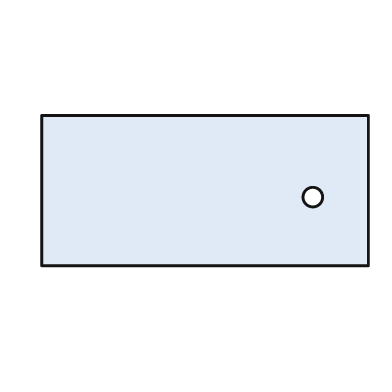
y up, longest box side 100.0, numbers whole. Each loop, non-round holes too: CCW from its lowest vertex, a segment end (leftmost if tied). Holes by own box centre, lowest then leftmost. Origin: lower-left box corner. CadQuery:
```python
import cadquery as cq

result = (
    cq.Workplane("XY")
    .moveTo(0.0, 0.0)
    .lineTo(100.0, 0.0)
    .lineTo(100.0, 46.0)
    .lineTo(0.0, 46.0)
    .close()
    .moveTo(83.0, 21.0)
    .circle(3.0)
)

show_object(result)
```